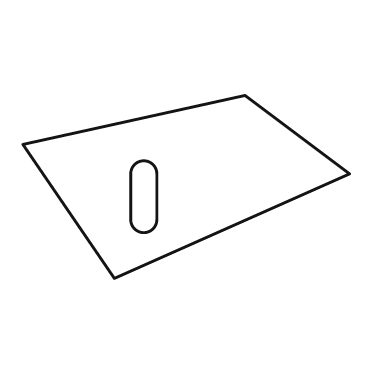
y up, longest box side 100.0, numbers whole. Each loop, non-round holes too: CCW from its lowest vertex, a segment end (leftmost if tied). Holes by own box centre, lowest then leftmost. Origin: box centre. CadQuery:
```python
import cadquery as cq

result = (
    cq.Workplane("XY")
    .moveTo(-22.0, -28.0)
    .lineTo(50.0, 4.0)
    .lineTo(18.0, 28.0)
    .lineTo(-50.0, 13.0)
    .close()
    .moveTo(-17.0, -10.0)
    .threePointArc((-13.0, -14.0), (-9.0, -10.0))
    .lineTo(-9.0, 4.0)
    .threePointArc((-13.0, 8.0), (-17.0, 4.0))
    .close()
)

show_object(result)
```